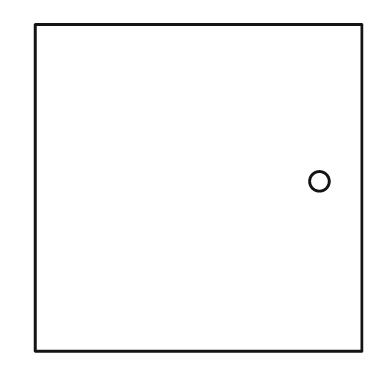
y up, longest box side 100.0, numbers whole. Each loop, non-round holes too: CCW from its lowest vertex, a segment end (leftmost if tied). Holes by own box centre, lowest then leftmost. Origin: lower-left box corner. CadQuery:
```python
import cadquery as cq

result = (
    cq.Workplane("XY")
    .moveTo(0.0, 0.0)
    .lineTo(100.0, 0.0)
    .lineTo(100.0, 100.0)
    .lineTo(0.0, 100.0)
    .close()
    .moveTo(87.0, 52.0)
    .circle(3.0)
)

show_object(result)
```